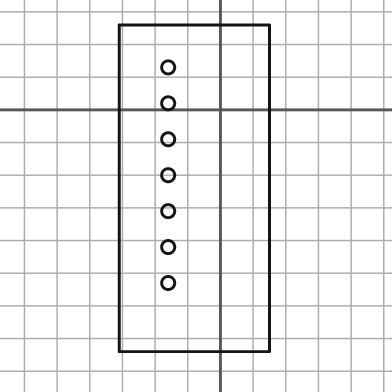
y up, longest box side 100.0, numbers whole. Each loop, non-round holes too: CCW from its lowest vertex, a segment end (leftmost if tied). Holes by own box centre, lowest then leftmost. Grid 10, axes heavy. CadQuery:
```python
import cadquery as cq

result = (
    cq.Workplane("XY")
    .moveTo(-31.0, -74.0)
    .lineTo(15.0, -74.0)
    .lineTo(15.0, 26.0)
    .lineTo(-31.0, 26.0)
    .close()
    .moveTo(-16.0, -53.0)
    .circle(2.0)
    .moveTo(-16.0, -42.0)
    .circle(2.0)
    .moveTo(-16.0, -31.0)
    .circle(2.0)
    .moveTo(-16.0, -20.0)
    .circle(2.0)
    .moveTo(-16.0, -9.0)
    .circle(2.0)
    .moveTo(-16.0, 2.0)
    .circle(2.0)
    .moveTo(-16.0, 13.0)
    .circle(2.0)
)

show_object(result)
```